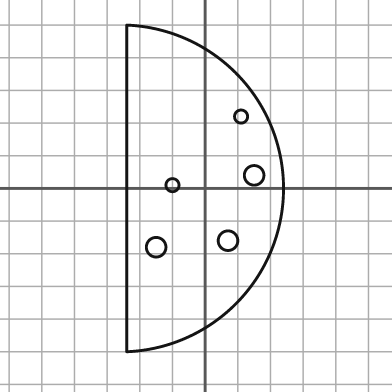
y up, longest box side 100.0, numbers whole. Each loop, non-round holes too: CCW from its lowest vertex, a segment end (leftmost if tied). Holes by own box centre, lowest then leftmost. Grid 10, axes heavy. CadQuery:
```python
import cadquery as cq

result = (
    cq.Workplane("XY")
    .moveTo(-24.0, -50.0)
    .threePointArc((24.0, 0.0), (-24.0, 50.0))
    .close()
    .moveTo(-15.0, -18.0)
    .circle(3.0)
    .moveTo(7.0, -16.0)
    .circle(3.0)
    .moveTo(-10.0, 1.0)
    .circle(2.0)
    .moveTo(15.0, 4.0)
    .circle(3.0)
    .moveTo(11.0, 22.0)
    .circle(2.0)
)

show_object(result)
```